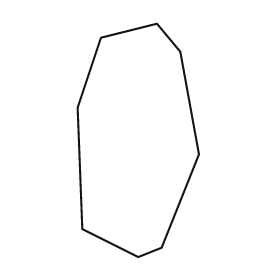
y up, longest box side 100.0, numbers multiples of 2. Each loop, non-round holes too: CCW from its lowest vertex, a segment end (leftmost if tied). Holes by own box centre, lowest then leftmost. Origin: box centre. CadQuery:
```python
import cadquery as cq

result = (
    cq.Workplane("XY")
    .moveTo(0.0, -50.0)
    .lineTo(10.0, -46.0)
    .lineTo(26.0, -6.0)
    .lineTo(18.0, 38.0)
    .lineTo(8.0, 50.0)
    .lineTo(-16.0, 44.0)
    .lineTo(-26.0, 14.0)
    .lineTo(-24.0, -38.0)
    .close()
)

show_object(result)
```